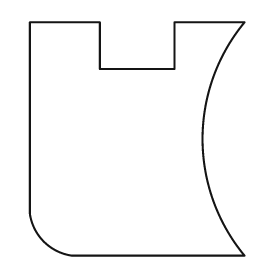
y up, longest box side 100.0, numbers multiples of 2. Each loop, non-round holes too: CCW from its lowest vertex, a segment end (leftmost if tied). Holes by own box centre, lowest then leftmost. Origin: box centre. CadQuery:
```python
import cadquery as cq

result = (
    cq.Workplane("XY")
    .moveTo(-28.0, -50.0)
    .lineTo(46.0, -50.0)
    .threePointArc((28.0, 0.0), (46.0, 50.0))
    .lineTo(16.0, 50.0)
    .lineTo(16.0, 30.0)
    .lineTo(-16.0, 30.0)
    .lineTo(-16.0, 50.0)
    .lineTo(-46.0, 50.0)
    .lineTo(-46.0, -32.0)
    .threePointArc((-40.0, -44.0), (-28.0, -50.0))
    .close()
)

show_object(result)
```